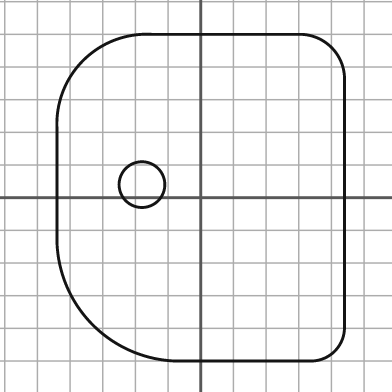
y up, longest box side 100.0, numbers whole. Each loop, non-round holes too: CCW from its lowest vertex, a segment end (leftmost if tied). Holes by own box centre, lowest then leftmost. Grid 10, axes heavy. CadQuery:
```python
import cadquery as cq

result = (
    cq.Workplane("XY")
    .moveTo(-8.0, -50.0)
    .lineTo(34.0, -50.0)
    .threePointArc((41.0, -47.0), (44.0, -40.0))
    .lineTo(44.0, 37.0)
    .threePointArc((40.0, 46.0), (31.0, 50.0))
    .lineTo(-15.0, 50.0)
    .threePointArc((-36.0, 42.0), (-44.0, 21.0))
    .lineTo(-44.0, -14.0)
    .threePointArc((-33.0, -39.0), (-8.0, -50.0))
    .close()
    .moveTo(-18.0, 4.0)
    .circle(7.0)
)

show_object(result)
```